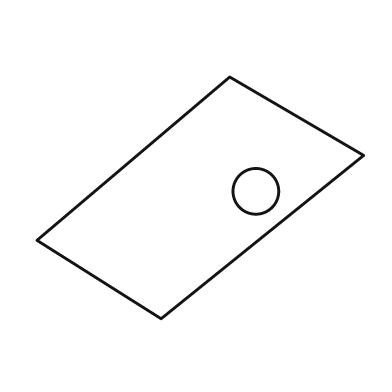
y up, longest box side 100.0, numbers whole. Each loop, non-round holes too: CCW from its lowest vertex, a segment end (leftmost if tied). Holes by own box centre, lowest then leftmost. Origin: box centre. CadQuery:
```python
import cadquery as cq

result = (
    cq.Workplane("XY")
    .moveTo(-12.0, -37.0)
    .lineTo(50.0, 13.0)
    .lineTo(9.0, 37.0)
    .lineTo(-50.0, -13.0)
    .close()
    .moveTo(17.0, 2.0)
    .circle(7.0)
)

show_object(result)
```